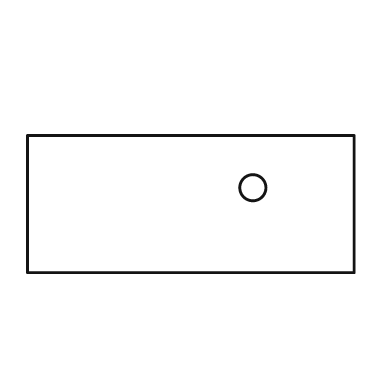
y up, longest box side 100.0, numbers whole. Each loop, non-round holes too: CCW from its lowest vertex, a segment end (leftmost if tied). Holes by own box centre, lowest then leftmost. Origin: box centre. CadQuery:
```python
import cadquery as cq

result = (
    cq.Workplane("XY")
    .moveTo(-50.0, -21.0)
    .lineTo(50.0, -21.0)
    .lineTo(50.0, 21.0)
    .lineTo(-50.0, 21.0)
    .close()
    .moveTo(19.0, 5.0)
    .circle(4.0)
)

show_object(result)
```